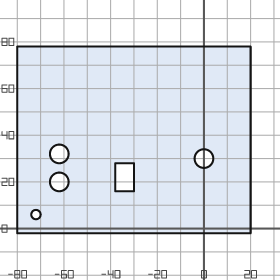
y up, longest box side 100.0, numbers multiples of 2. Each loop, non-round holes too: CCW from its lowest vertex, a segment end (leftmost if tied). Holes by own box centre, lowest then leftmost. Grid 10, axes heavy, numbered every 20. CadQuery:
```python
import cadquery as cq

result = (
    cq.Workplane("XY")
    .moveTo(-80.0, -2.0)
    .lineTo(20.0, -2.0)
    .lineTo(20.0, 78.0)
    .lineTo(-80.0, 78.0)
    .close()
    .moveTo(-72.0, 6.0)
    .circle(2.0)
    .moveTo(-62.0, 20.0)
    .circle(4.0)
    .moveTo(-38.0, 16.0)
    .lineTo(-30.0, 16.0)
    .lineTo(-30.0, 28.0)
    .lineTo(-38.0, 28.0)
    .close()
    .moveTo(0.0, 30.0)
    .circle(4.0)
    .moveTo(-62.0, 32.0)
    .circle(4.0)
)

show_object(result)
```